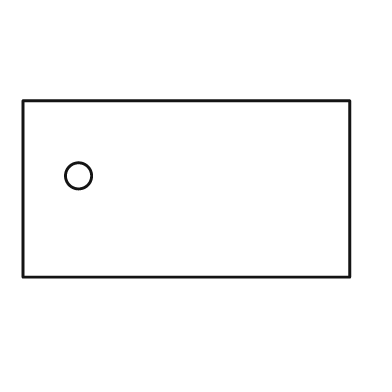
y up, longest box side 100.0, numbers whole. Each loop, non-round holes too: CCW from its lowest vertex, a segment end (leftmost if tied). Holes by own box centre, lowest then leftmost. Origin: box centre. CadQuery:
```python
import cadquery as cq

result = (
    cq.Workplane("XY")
    .moveTo(-50.0, -27.0)
    .lineTo(50.0, -27.0)
    .lineTo(50.0, 27.0)
    .lineTo(-50.0, 27.0)
    .close()
    .moveTo(-33.0, 4.0)
    .circle(4.0)
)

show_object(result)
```